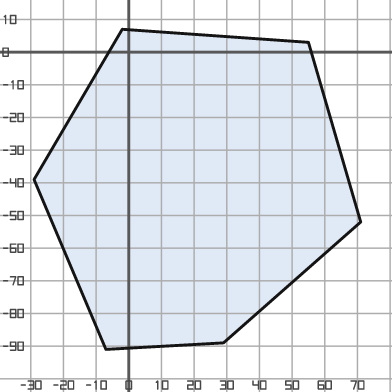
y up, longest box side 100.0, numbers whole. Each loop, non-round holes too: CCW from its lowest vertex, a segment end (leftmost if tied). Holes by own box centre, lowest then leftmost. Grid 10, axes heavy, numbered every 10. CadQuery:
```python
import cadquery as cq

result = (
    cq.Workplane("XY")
    .moveTo(-7.0, -91.0)
    .lineTo(29.0, -89.0)
    .lineTo(71.0, -52.0)
    .lineTo(55.0, 3.0)
    .lineTo(-2.0, 7.0)
    .lineTo(-29.0, -39.0)
    .close()
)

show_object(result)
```